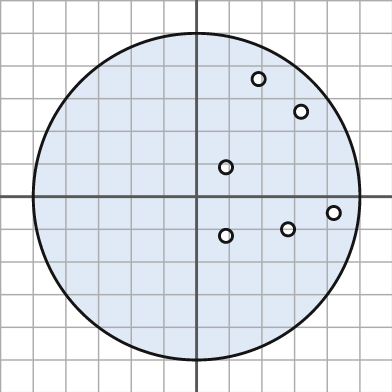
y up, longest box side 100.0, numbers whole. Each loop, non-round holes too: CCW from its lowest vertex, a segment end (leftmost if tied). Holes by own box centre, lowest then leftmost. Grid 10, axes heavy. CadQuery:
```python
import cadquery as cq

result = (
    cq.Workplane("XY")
    .moveTo(0.0, 0.0)
    .circle(50.0)
    .moveTo(9.0, -12.0)
    .circle(2.0)
    .moveTo(28.0, -10.0)
    .circle(2.0)
    .moveTo(42.0, -5.0)
    .circle(2.0)
    .moveTo(9.0, 9.0)
    .circle(2.0)
    .moveTo(32.0, 26.0)
    .circle(2.0)
    .moveTo(19.0, 36.0)
    .circle(2.0)
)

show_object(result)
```